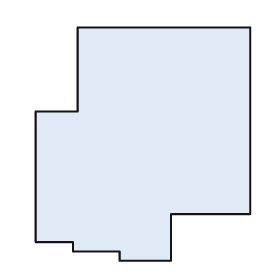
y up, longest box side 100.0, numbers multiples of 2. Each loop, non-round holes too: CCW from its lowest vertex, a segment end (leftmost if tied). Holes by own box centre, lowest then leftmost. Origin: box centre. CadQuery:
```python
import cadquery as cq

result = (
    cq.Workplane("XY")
    .moveTo(-10.0, -50.0)
    .lineTo(12.0, -50.0)
    .lineTo(12.0, -30.0)
    .lineTo(46.0, -30.0)
    .lineTo(46.0, 50.0)
    .lineTo(-28.0, 50.0)
    .lineTo(-28.0, 14.0)
    .lineTo(-46.0, 14.0)
    .lineTo(-46.0, -42.0)
    .lineTo(-30.0, -42.0)
    .lineTo(-30.0, -46.0)
    .lineTo(-10.0, -46.0)
    .close()
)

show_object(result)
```